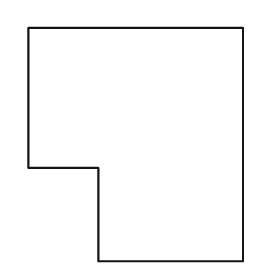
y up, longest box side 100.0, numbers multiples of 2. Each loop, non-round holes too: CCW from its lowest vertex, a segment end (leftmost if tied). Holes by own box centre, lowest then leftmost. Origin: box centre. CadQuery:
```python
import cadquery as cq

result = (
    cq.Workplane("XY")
    .moveTo(-16.0, -50.0)
    .lineTo(46.0, -50.0)
    .lineTo(46.0, 50.0)
    .lineTo(-46.0, 50.0)
    .lineTo(-46.0, -10.0)
    .lineTo(-16.0, -10.0)
    .close()
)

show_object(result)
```